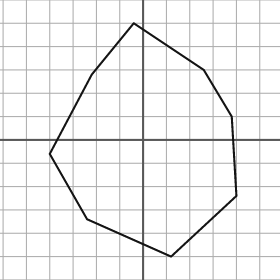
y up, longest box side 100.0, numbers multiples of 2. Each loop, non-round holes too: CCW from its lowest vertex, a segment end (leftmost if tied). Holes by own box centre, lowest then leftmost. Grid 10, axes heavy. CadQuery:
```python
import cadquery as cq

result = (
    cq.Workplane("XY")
    .moveTo(12.0, -50.0)
    .lineTo(40.0, -24.0)
    .lineTo(38.0, 10.0)
    .lineTo(26.0, 30.0)
    .lineTo(-4.0, 50.0)
    .lineTo(-22.0, 28.0)
    .lineTo(-40.0, -6.0)
    .lineTo(-24.0, -34.0)
    .close()
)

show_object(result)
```